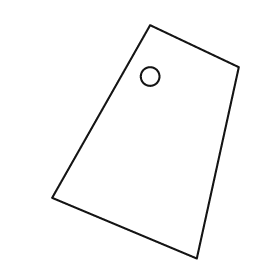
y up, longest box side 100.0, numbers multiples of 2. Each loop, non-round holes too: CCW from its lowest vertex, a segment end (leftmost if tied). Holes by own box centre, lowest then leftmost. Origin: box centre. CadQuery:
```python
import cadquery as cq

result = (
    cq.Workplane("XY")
    .moveTo(22.0, -50.0)
    .lineTo(40.0, 32.0)
    .lineTo(2.0, 50.0)
    .lineTo(-40.0, -24.0)
    .close()
    .moveTo(2.0, 28.0)
    .circle(4.0)
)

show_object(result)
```